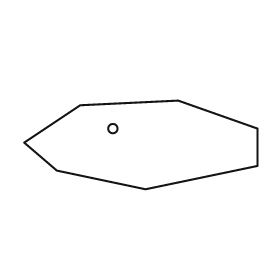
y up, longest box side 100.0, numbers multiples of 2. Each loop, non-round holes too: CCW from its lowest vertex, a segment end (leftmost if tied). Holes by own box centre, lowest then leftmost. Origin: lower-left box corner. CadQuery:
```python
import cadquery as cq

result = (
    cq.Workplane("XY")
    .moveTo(52.0, 0.0)
    .lineTo(100.0, 10.0)
    .lineTo(100.0, 26.0)
    .lineTo(66.0, 38.0)
    .lineTo(24.0, 36.0)
    .lineTo(0.0, 20.0)
    .lineTo(14.0, 8.0)
    .close()
    .moveTo(38.0, 26.0)
    .circle(2.0)
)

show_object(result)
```